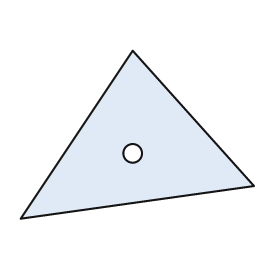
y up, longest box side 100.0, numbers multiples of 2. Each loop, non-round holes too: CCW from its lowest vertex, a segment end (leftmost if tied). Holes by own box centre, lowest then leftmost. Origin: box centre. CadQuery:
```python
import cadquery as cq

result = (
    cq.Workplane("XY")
    .moveTo(-50.0, -36.0)
    .lineTo(50.0, -22.0)
    .lineTo(-2.0, 36.0)
    .close()
    .moveTo(-2.0, -8.0)
    .circle(4.0)
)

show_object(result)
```